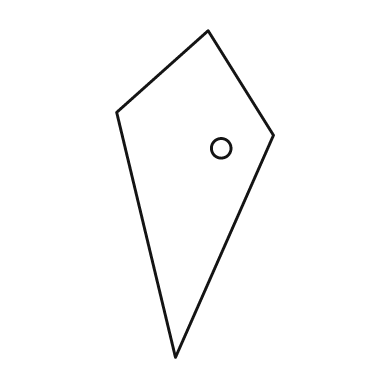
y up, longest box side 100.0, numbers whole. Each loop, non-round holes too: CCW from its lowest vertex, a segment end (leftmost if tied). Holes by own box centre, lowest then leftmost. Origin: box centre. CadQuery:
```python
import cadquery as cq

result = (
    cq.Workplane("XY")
    .moveTo(-6.0, -50.0)
    .lineTo(24.0, 18.0)
    .lineTo(4.0, 50.0)
    .lineTo(-24.0, 25.0)
    .close()
    .moveTo(8.0, 14.0)
    .circle(3.0)
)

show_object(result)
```